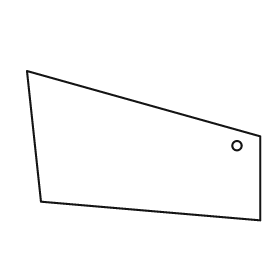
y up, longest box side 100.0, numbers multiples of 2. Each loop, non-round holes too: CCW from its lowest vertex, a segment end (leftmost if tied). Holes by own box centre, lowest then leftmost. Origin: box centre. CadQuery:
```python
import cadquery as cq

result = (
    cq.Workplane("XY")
    .moveTo(50.0, -32.0)
    .lineTo(50.0, 4.0)
    .lineTo(-50.0, 32.0)
    .lineTo(-44.0, -24.0)
    .close()
    .moveTo(40.0, 0.0)
    .circle(2.0)
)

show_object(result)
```